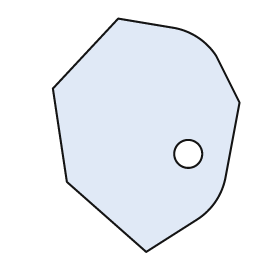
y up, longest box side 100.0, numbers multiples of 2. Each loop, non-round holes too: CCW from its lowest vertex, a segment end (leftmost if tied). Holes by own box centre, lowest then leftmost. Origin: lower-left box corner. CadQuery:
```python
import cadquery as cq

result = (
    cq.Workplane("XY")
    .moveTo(40.0, 0.0)
    .lineTo(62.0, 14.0)
    .threePointArc((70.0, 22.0), (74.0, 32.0))
    .lineTo(80.0, 64.0)
    .lineTo(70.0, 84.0)
    .threePointArc((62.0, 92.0), (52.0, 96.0))
    .lineTo(28.0, 100.0)
    .lineTo(0.0, 70.0)
    .lineTo(6.0, 30.0)
    .close()
    .moveTo(58.0, 42.0)
    .circle(6.0)
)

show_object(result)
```